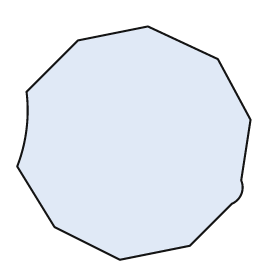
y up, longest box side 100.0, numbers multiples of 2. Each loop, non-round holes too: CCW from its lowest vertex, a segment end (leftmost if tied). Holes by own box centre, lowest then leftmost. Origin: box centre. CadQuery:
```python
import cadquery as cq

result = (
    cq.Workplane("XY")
    .moveTo(-6.0, -50.0)
    .lineTo(24.0, -44.0)
    .lineTo(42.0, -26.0)
    .threePointArc((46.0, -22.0), (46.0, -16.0))
    .lineTo(50.0, 10.0)
    .lineTo(36.0, 36.0)
    .lineTo(6.0, 50.0)
    .lineTo(-24.0, 44.0)
    .lineTo(-46.0, 22.0)
    .threePointArc((-46.0, 6.0), (-50.0, -10.0))
    .lineTo(-34.0, -36.0)
    .close()
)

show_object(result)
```